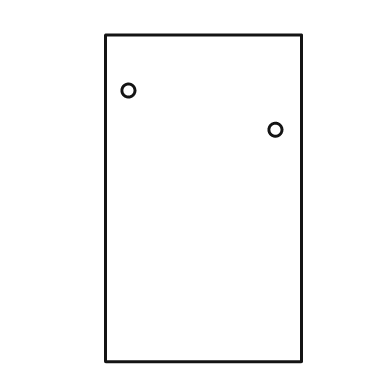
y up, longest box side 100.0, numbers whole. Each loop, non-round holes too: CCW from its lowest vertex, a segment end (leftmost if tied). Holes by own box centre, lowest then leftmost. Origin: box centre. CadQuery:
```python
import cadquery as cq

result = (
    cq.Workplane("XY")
    .moveTo(-30.0, -50.0)
    .lineTo(30.0, -50.0)
    .lineTo(30.0, 50.0)
    .lineTo(-30.0, 50.0)
    .close()
    .moveTo(22.0, 21.0)
    .circle(2.0)
    .moveTo(-23.0, 33.0)
    .circle(2.0)
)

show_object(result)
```